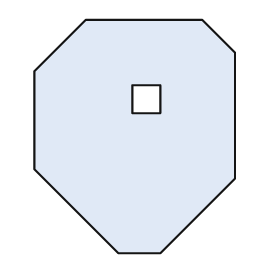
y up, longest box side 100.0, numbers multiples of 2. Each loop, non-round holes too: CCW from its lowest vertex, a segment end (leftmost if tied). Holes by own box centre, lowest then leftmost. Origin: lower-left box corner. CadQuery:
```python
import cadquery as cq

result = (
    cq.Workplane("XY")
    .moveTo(36.0, 0.0)
    .lineTo(54.0, 0.0)
    .lineTo(86.0, 32.0)
    .lineTo(86.0, 86.0)
    .lineTo(72.0, 100.0)
    .lineTo(22.0, 100.0)
    .lineTo(0.0, 78.0)
    .lineTo(0.0, 36.0)
    .close()
    .moveTo(42.0, 60.0)
    .lineTo(54.0, 60.0)
    .lineTo(54.0, 72.0)
    .lineTo(42.0, 72.0)
    .close()
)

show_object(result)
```